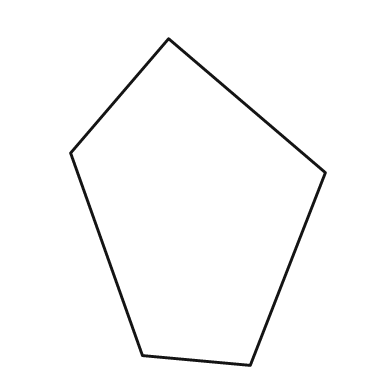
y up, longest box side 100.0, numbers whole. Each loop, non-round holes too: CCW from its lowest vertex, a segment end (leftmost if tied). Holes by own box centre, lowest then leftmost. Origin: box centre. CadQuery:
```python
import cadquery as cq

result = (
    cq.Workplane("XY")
    .moveTo(16.0, -50.0)
    .lineTo(39.0, 9.0)
    .lineTo(-9.0, 50.0)
    .lineTo(-39.0, 15.0)
    .lineTo(-17.0, -47.0)
    .close()
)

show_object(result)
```